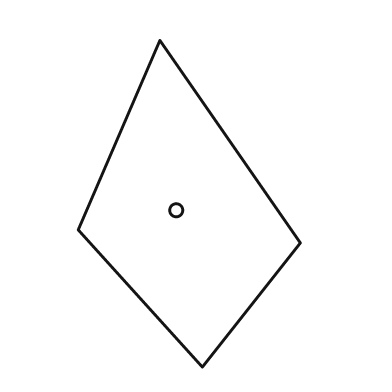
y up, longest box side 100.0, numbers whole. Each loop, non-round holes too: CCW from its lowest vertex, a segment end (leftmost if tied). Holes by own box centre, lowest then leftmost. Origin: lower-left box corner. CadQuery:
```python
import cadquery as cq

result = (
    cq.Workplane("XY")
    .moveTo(38.0, 0.0)
    .lineTo(68.0, 38.0)
    .lineTo(25.0, 100.0)
    .lineTo(0.0, 42.0)
    .close()
    .moveTo(30.0, 48.0)
    .circle(2.0)
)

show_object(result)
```